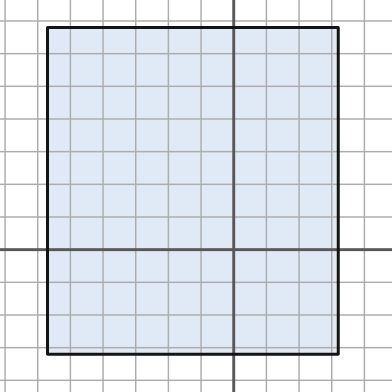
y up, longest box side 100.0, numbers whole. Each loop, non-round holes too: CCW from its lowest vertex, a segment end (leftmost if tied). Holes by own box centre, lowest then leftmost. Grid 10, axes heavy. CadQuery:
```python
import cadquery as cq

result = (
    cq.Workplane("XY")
    .moveTo(-57.0, -32.0)
    .lineTo(32.0, -32.0)
    .lineTo(32.0, 68.0)
    .lineTo(-57.0, 68.0)
    .close()
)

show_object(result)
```